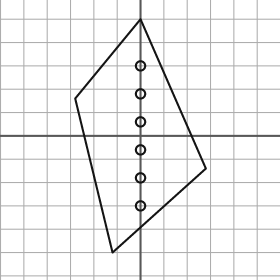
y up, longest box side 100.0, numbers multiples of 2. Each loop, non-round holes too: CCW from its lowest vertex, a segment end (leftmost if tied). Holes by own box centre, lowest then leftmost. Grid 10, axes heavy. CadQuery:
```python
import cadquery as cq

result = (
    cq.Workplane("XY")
    .moveTo(-12.0, -50.0)
    .lineTo(28.0, -14.0)
    .lineTo(0.0, 50.0)
    .lineTo(-28.0, 16.0)
    .close()
    .moveTo(0.0, -30.0)
    .circle(2.0)
    .moveTo(0.0, -18.0)
    .circle(2.0)
    .moveTo(0.0, -6.0)
    .circle(2.0)
    .moveTo(0.0, 6.0)
    .circle(2.0)
    .moveTo(0.0, 18.0)
    .circle(2.0)
    .moveTo(0.0, 30.0)
    .circle(2.0)
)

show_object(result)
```